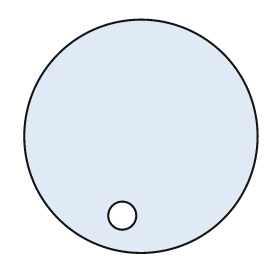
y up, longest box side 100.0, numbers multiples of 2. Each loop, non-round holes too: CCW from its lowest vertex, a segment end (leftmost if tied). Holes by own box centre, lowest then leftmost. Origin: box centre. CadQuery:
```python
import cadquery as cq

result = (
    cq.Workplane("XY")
    .moveTo(0.0, 0.0)
    .circle(50.0)
    .moveTo(-8.0, -34.0)
    .circle(6.0)
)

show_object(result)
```